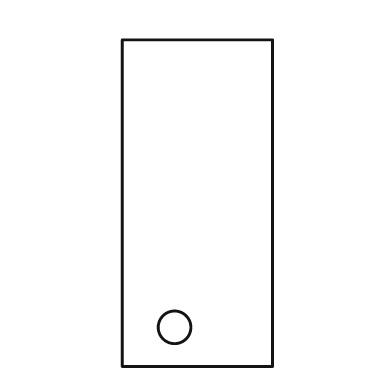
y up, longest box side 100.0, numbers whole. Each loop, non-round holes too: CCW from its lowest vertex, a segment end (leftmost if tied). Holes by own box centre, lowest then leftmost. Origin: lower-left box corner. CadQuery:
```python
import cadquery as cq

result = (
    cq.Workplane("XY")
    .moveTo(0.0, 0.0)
    .lineTo(46.0, 0.0)
    .lineTo(46.0, 100.0)
    .lineTo(0.0, 100.0)
    .close()
    .moveTo(16.0, 12.0)
    .circle(5.0)
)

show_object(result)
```